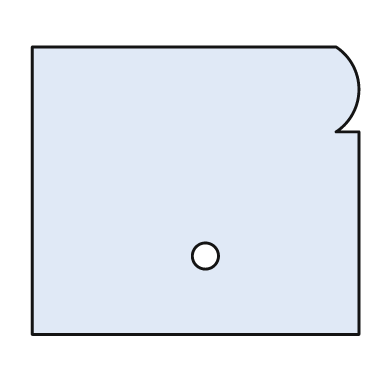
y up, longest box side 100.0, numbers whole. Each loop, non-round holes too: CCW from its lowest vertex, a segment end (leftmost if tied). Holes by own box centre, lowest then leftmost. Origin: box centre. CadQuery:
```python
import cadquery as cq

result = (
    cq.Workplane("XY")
    .moveTo(-50.0, -44.0)
    .lineTo(50.0, -44.0)
    .lineTo(50.0, 18.0)
    .lineTo(43.0, 18.0)
    .threePointArc((50.0, 31.0), (43.0, 44.0))
    .lineTo(-50.0, 44.0)
    .close()
    .moveTo(3.0, -20.0)
    .circle(4.0)
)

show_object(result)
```